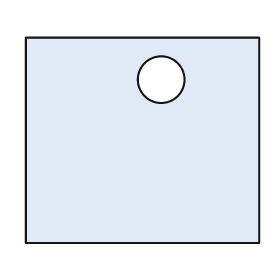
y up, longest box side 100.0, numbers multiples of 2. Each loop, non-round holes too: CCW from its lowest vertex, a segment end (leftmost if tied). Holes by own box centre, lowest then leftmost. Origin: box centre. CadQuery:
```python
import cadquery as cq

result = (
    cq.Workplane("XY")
    .moveTo(-50.0, -44.0)
    .lineTo(50.0, -44.0)
    .lineTo(50.0, 44.0)
    .lineTo(-50.0, 44.0)
    .close()
    .moveTo(8.0, 26.0)
    .circle(10.0)
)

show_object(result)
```